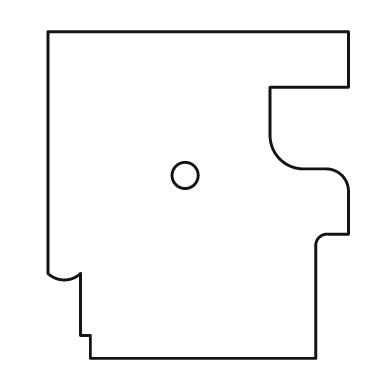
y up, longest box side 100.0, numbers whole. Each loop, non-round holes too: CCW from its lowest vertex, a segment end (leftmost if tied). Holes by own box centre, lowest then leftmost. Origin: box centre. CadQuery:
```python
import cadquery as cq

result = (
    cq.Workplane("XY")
    .moveTo(-33.0, -50.0)
    .lineTo(36.0, -50.0)
    .lineTo(36.0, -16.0)
    .threePointArc((37.0, -13.0), (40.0, -12.0))
    .lineTo(46.0, -12.0)
    .lineTo(46.0, 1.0)
    .threePointArc((44.0, 6.0), (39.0, 8.0))
    .lineTo(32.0, 8.0)
    .threePointArc((25.0, 11.0), (22.0, 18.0))
    .lineTo(22.0, 33.0)
    .lineTo(46.0, 33.0)
    .lineTo(46.0, 50.0)
    .lineTo(-46.0, 50.0)
    .lineTo(-46.0, -24.0)
    .threePointArc((-41.0, -26.0), (-36.0, -24.0))
    .lineTo(-36.0, -43.0)
    .lineTo(-33.0, -43.0)
    .close()
    .moveTo(-4.0, 6.0)
    .circle(4.0)
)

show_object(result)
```